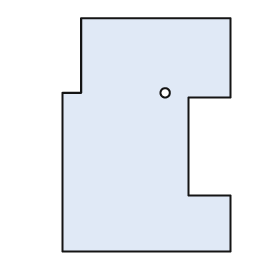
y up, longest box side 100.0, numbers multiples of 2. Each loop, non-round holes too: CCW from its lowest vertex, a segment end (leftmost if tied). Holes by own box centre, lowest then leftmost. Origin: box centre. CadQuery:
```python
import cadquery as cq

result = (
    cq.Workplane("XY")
    .moveTo(-36.0, -50.0)
    .lineTo(36.0, -50.0)
    .lineTo(36.0, -26.0)
    .lineTo(18.0, -26.0)
    .lineTo(18.0, 16.0)
    .lineTo(36.0, 16.0)
    .lineTo(36.0, 50.0)
    .lineTo(-28.0, 50.0)
    .lineTo(-28.0, 18.0)
    .lineTo(-36.0, 18.0)
    .close()
    .moveTo(8.0, 18.0)
    .circle(2.0)
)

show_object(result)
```